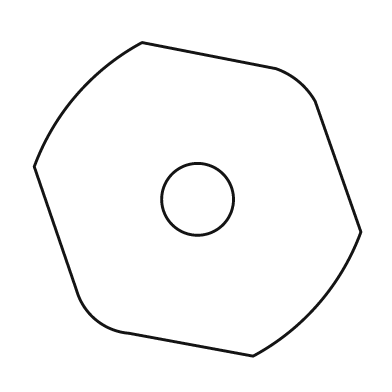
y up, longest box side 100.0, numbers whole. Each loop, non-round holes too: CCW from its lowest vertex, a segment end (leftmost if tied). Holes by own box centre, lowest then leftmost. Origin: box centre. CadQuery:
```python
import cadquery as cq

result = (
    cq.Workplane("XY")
    .moveTo(17.0, -48.0)
    .threePointArc((37.0, -32.0), (50.0, -10.0))
    .lineTo(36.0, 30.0)
    .threePointArc((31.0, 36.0), (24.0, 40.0))
    .lineTo(-17.0, 48.0)
    .threePointArc((-37.0, 32.0), (-50.0, 10.0))
    .lineTo(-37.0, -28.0)
    .threePointArc((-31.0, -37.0), (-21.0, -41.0))
    .close()
    .moveTo(0.0, 0.0)
    .circle(11.0)
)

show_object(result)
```